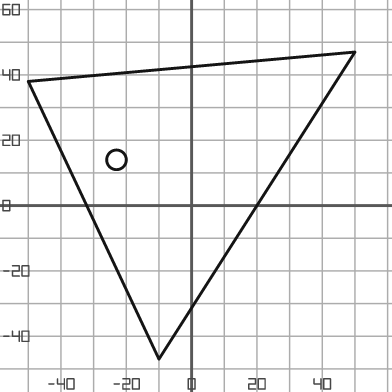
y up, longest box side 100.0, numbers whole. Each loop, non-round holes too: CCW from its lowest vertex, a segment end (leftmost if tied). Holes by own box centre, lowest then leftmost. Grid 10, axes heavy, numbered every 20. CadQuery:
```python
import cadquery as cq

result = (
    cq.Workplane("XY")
    .moveTo(-10.0, -47.0)
    .lineTo(50.0, 47.0)
    .lineTo(-50.0, 38.0)
    .close()
    .moveTo(-23.0, 14.0)
    .circle(3.0)
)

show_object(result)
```